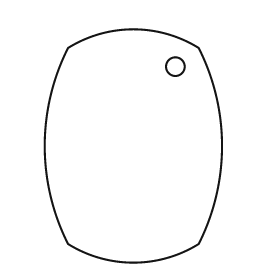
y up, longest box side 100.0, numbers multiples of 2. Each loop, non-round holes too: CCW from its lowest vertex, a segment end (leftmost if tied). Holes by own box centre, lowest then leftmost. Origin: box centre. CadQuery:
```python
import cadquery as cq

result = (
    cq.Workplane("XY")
    .moveTo(-28.0, -42.0)
    .threePointArc((0.0, -50.0), (28.0, -42.0))
    .threePointArc((38.0, 0.0), (28.0, 42.0))
    .threePointArc((0.0, 50.0), (-28.0, 42.0))
    .threePointArc((-38.0, 0.0), (-28.0, -42.0))
    .close()
    .moveTo(18.0, 34.0)
    .circle(4.0)
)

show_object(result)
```